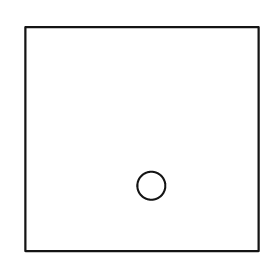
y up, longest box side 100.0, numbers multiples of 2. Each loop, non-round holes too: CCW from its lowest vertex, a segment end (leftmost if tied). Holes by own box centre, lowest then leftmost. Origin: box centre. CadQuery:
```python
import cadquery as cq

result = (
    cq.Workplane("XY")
    .moveTo(-50.0, -48.0)
    .lineTo(50.0, -48.0)
    .lineTo(50.0, 48.0)
    .lineTo(-50.0, 48.0)
    .close()
    .moveTo(4.0, -20.0)
    .circle(6.0)
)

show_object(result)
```